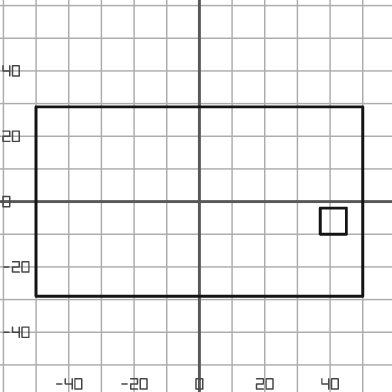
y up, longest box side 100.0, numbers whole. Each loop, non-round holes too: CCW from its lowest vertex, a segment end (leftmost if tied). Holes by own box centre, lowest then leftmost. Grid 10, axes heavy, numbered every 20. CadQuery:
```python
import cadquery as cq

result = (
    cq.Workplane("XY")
    .moveTo(-50.0, -29.0)
    .lineTo(50.0, -29.0)
    .lineTo(50.0, 29.0)
    .lineTo(-50.0, 29.0)
    .close()
    .moveTo(37.0, -10.0)
    .lineTo(45.0, -10.0)
    .lineTo(45.0, -2.0)
    .lineTo(37.0, -2.0)
    .close()
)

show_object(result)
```